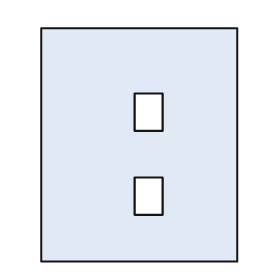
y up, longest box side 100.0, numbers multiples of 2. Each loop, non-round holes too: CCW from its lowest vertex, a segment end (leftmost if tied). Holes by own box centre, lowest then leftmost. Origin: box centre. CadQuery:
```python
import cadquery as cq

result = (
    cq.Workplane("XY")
    .moveTo(-42.0, -50.0)
    .lineTo(42.0, -50.0)
    .lineTo(42.0, 50.0)
    .lineTo(-42.0, 50.0)
    .close()
    .moveTo(-2.0, -30.0)
    .lineTo(10.0, -30.0)
    .lineTo(10.0, -14.0)
    .lineTo(-2.0, -14.0)
    .close()
    .moveTo(-2.0, 6.0)
    .lineTo(10.0, 6.0)
    .lineTo(10.0, 22.0)
    .lineTo(-2.0, 22.0)
    .close()
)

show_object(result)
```